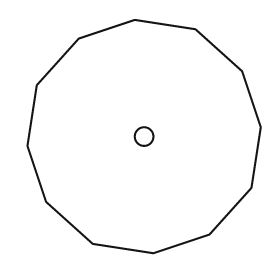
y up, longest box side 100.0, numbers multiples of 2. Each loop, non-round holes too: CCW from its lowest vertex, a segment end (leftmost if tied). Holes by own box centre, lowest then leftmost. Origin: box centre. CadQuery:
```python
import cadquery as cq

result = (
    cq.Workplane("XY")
    .moveTo(4.0, -50.0)
    .lineTo(28.0, -42.0)
    .lineTo(46.0, -22.0)
    .lineTo(50.0, 4.0)
    .lineTo(42.0, 28.0)
    .lineTo(22.0, 46.0)
    .lineTo(-4.0, 50.0)
    .lineTo(-28.0, 42.0)
    .lineTo(-46.0, 22.0)
    .lineTo(-50.0, -4.0)
    .lineTo(-42.0, -28.0)
    .lineTo(-22.0, -46.0)
    .close()
    .moveTo(0.0, 0.0)
    .circle(4.0)
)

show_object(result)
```